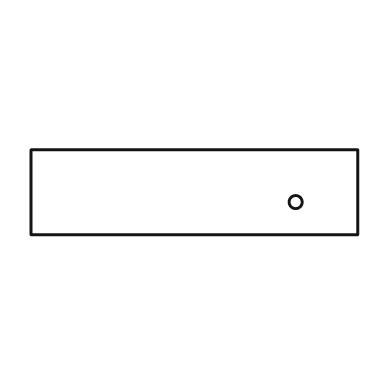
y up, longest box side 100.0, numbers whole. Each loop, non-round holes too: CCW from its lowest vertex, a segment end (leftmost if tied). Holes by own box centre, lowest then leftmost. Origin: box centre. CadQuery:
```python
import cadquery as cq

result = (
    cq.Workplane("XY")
    .moveTo(-50.0, -13.0)
    .lineTo(50.0, -13.0)
    .lineTo(50.0, 13.0)
    .lineTo(-50.0, 13.0)
    .close()
    .moveTo(31.0, -3.0)
    .circle(2.0)
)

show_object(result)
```